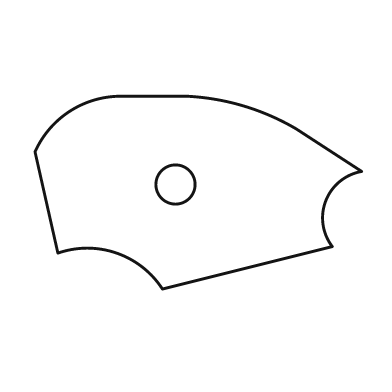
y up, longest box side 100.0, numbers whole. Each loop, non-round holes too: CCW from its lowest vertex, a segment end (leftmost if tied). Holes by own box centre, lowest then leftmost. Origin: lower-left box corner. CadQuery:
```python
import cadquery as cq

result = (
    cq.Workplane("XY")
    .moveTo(39.0, 0.0)
    .lineTo(91.0, 13.0)
    .threePointArc((89.0, 27.0), (100.0, 36.0))
    .lineTo(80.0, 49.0)
    .threePointArc((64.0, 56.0), (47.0, 59.0))
    .lineTo(25.0, 59.0)
    .threePointArc((10.0, 54.0), (0.0, 42.0))
    .lineTo(7.0, 11.0)
    .threePointArc((25.0, 11.0), (39.0, 0.0))
    .close()
    .moveTo(43.0, 32.0)
    .circle(6.0)
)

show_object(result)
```